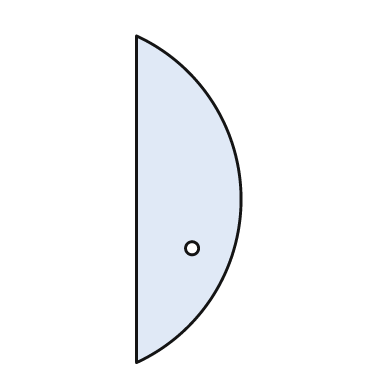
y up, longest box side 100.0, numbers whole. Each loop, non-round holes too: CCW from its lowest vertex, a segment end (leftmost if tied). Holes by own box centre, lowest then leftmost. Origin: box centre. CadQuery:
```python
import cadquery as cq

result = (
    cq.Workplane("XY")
    .moveTo(-16.0, -50.0)
    .threePointArc((16.0, 0.0), (-16.0, 50.0))
    .close()
    .moveTo(1.0, -15.0)
    .circle(2.0)
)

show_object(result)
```